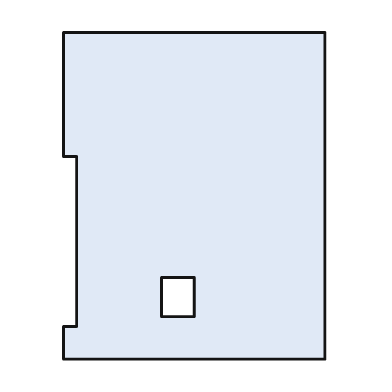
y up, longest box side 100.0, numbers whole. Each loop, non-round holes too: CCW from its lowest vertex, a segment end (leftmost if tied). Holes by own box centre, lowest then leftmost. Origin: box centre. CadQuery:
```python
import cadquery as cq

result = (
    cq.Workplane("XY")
    .moveTo(-40.0, -50.0)
    .lineTo(40.0, -50.0)
    .lineTo(40.0, 50.0)
    .lineTo(-40.0, 50.0)
    .lineTo(-40.0, 12.0)
    .lineTo(-36.0, 12.0)
    .lineTo(-36.0, -40.0)
    .lineTo(-40.0, -40.0)
    .close()
    .moveTo(-10.0, -37.0)
    .lineTo(0.0, -37.0)
    .lineTo(0.0, -25.0)
    .lineTo(-10.0, -25.0)
    .close()
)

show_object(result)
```